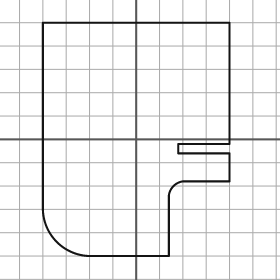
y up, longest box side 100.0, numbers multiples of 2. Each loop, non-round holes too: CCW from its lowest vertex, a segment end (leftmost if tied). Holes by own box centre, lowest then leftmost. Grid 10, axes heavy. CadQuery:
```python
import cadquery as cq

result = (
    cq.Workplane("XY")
    .moveTo(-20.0, -50.0)
    .lineTo(14.0, -50.0)
    .lineTo(14.0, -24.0)
    .threePointArc((16.0, -20.0), (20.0, -18.0))
    .lineTo(40.0, -18.0)
    .lineTo(40.0, -6.0)
    .lineTo(18.0, -6.0)
    .lineTo(18.0, -2.0)
    .lineTo(40.0, -2.0)
    .lineTo(40.0, 50.0)
    .lineTo(-40.0, 50.0)
    .lineTo(-40.0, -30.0)
    .threePointArc((-34.0, -44.0), (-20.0, -50.0))
    .close()
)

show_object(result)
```